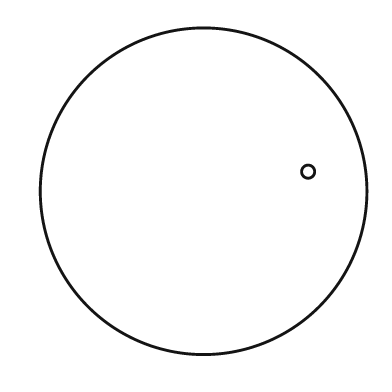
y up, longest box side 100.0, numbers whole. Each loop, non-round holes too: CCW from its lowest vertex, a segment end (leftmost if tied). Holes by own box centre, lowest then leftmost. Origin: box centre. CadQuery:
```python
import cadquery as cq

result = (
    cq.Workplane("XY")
    .moveTo(0.0, 0.0)
    .circle(50.0)
    .moveTo(32.0, 6.0)
    .circle(2.0)
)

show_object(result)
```